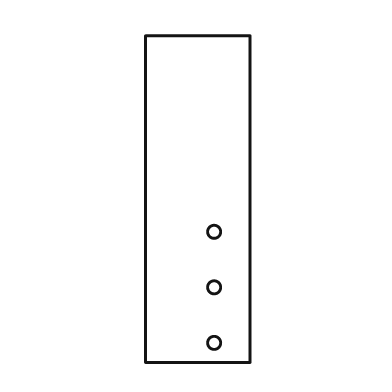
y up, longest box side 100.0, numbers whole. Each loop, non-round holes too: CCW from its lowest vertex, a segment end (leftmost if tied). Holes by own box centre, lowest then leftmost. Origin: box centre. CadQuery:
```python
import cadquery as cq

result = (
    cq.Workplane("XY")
    .moveTo(-16.0, -50.0)
    .lineTo(16.0, -50.0)
    .lineTo(16.0, 50.0)
    .lineTo(-16.0, 50.0)
    .close()
    .moveTo(5.0, -44.0)
    .circle(2.0)
    .moveTo(5.0, -27.0)
    .circle(2.0)
    .moveTo(5.0, -10.0)
    .circle(2.0)
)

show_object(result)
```